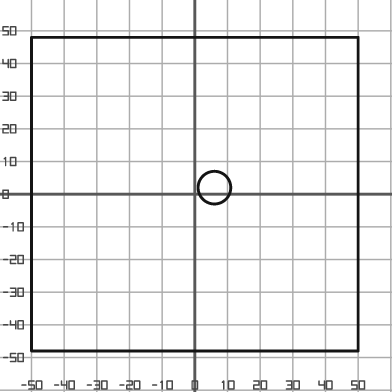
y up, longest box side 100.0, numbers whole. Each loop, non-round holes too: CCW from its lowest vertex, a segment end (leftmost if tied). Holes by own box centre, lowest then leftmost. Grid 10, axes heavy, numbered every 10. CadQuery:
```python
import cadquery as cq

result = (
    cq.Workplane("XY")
    .moveTo(-50.0, -48.0)
    .lineTo(50.0, -48.0)
    .lineTo(50.0, 48.0)
    .lineTo(-50.0, 48.0)
    .close()
    .moveTo(6.0, 2.0)
    .circle(5.0)
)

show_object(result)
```